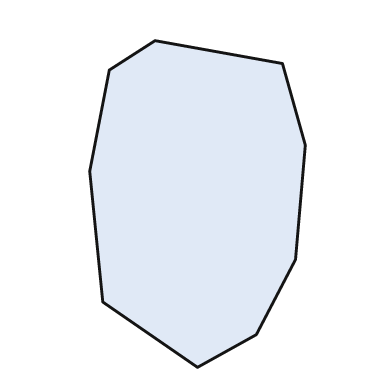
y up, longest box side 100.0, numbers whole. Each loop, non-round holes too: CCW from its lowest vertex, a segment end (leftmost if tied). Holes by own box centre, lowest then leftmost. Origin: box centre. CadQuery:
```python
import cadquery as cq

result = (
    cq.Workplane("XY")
    .moveTo(0.0, -50.0)
    .lineTo(18.0, -40.0)
    .lineTo(30.0, -17.0)
    .lineTo(33.0, 18.0)
    .lineTo(26.0, 43.0)
    .lineTo(-13.0, 50.0)
    .lineTo(-27.0, 41.0)
    .lineTo(-33.0, 10.0)
    .lineTo(-29.0, -30.0)
    .close()
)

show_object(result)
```